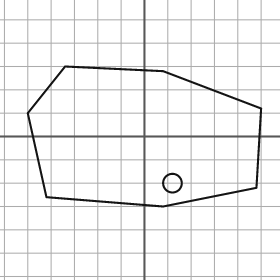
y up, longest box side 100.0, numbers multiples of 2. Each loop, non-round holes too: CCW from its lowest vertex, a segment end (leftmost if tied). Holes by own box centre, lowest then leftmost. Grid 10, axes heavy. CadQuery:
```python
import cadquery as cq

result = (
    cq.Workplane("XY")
    .moveTo(8.0, -30.0)
    .lineTo(48.0, -22.0)
    .lineTo(50.0, 12.0)
    .lineTo(8.0, 28.0)
    .lineTo(-34.0, 30.0)
    .lineTo(-50.0, 10.0)
    .lineTo(-42.0, -26.0)
    .close()
    .moveTo(12.0, -20.0)
    .circle(4.0)
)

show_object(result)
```